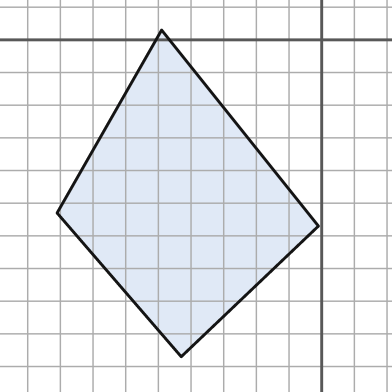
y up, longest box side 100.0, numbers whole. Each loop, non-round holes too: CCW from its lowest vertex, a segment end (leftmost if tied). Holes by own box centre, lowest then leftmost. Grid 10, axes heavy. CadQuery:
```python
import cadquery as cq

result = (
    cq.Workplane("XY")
    .moveTo(-43.0, -97.0)
    .lineTo(-1.0, -57.0)
    .lineTo(-49.0, 3.0)
    .lineTo(-81.0, -53.0)
    .close()
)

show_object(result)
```